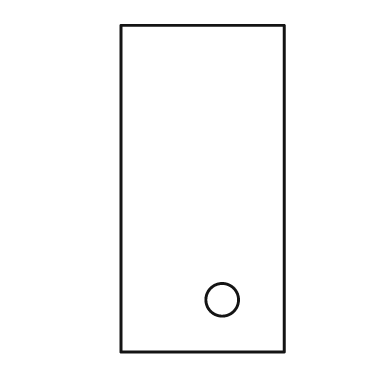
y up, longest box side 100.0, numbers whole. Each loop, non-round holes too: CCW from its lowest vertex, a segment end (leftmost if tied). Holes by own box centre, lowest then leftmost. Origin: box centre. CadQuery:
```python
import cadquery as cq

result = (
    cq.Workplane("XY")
    .moveTo(-25.0, -50.0)
    .lineTo(25.0, -50.0)
    .lineTo(25.0, 50.0)
    .lineTo(-25.0, 50.0)
    .close()
    .moveTo(6.0, -34.0)
    .circle(5.0)
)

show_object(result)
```